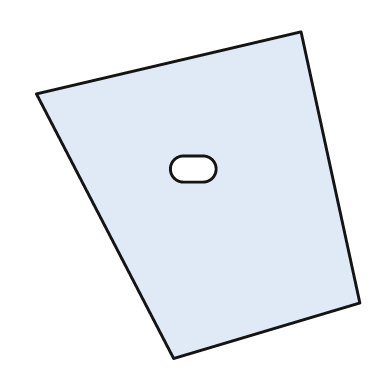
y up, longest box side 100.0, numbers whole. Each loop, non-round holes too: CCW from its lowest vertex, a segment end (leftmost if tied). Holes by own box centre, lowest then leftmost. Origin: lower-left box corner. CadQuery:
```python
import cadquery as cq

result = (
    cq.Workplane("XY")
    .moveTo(42.0, 0.0)
    .lineTo(99.0, 17.0)
    .lineTo(81.0, 100.0)
    .lineTo(0.0, 81.0)
    .close()
    .moveTo(45.0, 54.0)
    .lineTo(51.0, 54.0)
    .threePointArc((55.0, 58.0), (51.0, 62.0))
    .lineTo(45.0, 62.0)
    .threePointArc((41.0, 58.0), (45.0, 54.0))
    .close()
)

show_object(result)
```